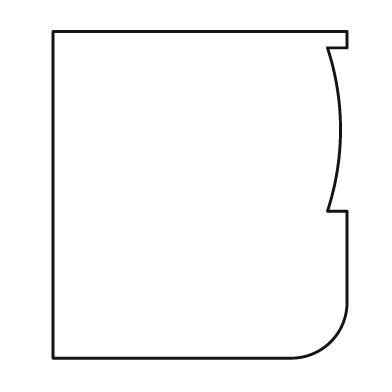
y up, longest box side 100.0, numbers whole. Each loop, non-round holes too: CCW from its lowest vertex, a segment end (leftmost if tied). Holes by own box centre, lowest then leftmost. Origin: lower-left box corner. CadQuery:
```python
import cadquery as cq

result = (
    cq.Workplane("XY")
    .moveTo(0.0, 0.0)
    .lineTo(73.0, 0.0)
    .threePointArc((85.0, 5.0), (90.0, 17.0))
    .lineTo(90.0, 45.0)
    .lineTo(84.0, 45.0)
    .threePointArc((88.0, 70.0), (84.0, 95.0))
    .lineTo(90.0, 95.0)
    .lineTo(90.0, 100.0)
    .lineTo(0.0, 100.0)
    .close()
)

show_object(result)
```